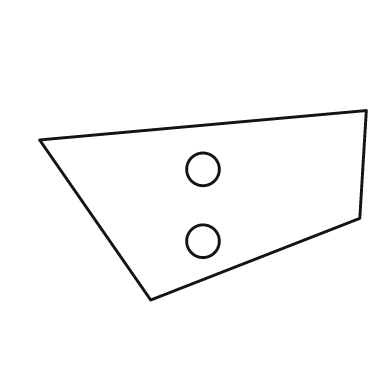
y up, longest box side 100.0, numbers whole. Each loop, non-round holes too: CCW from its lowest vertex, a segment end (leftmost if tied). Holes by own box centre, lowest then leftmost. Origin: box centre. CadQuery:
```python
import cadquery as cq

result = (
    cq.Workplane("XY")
    .moveTo(-16.0, -29.0)
    .lineTo(48.0, -4.0)
    .lineTo(50.0, 29.0)
    .lineTo(-50.0, 20.0)
    .close()
    .moveTo(0.0, -11.0)
    .circle(5.0)
    .moveTo(0.0, 11.0)
    .circle(5.0)
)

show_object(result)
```